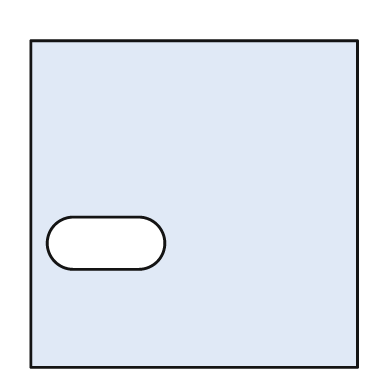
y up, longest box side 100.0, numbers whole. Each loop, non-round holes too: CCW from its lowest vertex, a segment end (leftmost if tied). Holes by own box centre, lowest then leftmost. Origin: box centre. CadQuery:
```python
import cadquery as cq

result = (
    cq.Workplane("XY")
    .moveTo(-50.0, -50.0)
    .lineTo(50.0, -50.0)
    .lineTo(50.0, 50.0)
    .lineTo(-50.0, 50.0)
    .close()
    .moveTo(-37.0, -20.0)
    .lineTo(-17.0, -20.0)
    .threePointArc((-9.0, -12.0), (-17.0, -4.0))
    .lineTo(-37.0, -4.0)
    .threePointArc((-45.0, -12.0), (-37.0, -20.0))
    .close()
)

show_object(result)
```